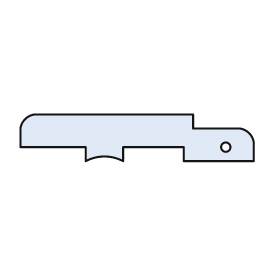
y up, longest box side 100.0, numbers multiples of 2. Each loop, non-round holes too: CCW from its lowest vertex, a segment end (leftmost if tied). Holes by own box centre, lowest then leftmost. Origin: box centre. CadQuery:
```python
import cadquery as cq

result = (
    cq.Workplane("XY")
    .moveTo(-22.0, -10.0)
    .threePointArc((-14.0, -8.0), (-6.0, -10.0))
    .lineTo(-6.0, -4.0)
    .lineTo(20.0, -4.0)
    .lineTo(20.0, -10.0)
    .lineTo(50.0, -10.0)
    .lineTo(50.0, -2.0)
    .threePointArc((48.0, 2.0), (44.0, 4.0))
    .lineTo(24.0, 4.0)
    .lineTo(24.0, 10.0)
    .lineTo(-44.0, 10.0)
    .threePointArc((-48.0, 8.0), (-50.0, 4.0))
    .lineTo(-50.0, -4.0)
    .lineTo(-22.0, -4.0)
    .close()
    .moveTo(38.0, -4.0)
    .circle(2.0)
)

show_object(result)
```